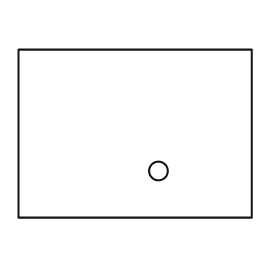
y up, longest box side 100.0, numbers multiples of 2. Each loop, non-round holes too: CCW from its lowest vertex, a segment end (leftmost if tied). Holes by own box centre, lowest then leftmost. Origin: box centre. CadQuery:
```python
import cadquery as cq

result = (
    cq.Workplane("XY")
    .moveTo(-50.0, -36.0)
    .lineTo(50.0, -36.0)
    .lineTo(50.0, 36.0)
    .lineTo(-50.0, 36.0)
    .close()
    .moveTo(10.0, -16.0)
    .circle(4.0)
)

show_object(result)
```